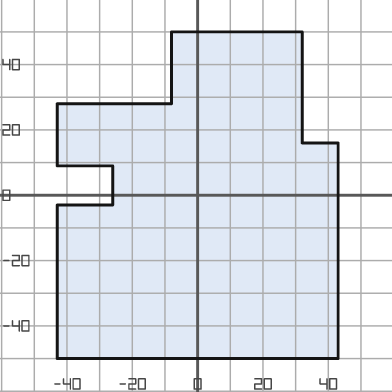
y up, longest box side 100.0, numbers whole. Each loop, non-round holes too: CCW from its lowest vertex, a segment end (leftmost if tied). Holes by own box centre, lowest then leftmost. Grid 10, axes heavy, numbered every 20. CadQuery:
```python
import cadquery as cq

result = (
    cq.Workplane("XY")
    .moveTo(-43.0, -50.0)
    .lineTo(43.0, -50.0)
    .lineTo(43.0, 16.0)
    .lineTo(32.0, 16.0)
    .lineTo(32.0, 50.0)
    .lineTo(-8.0, 50.0)
    .lineTo(-8.0, 28.0)
    .lineTo(-43.0, 28.0)
    .lineTo(-43.0, 9.0)
    .lineTo(-26.0, 9.0)
    .lineTo(-26.0, -3.0)
    .lineTo(-43.0, -3.0)
    .close()
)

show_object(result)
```